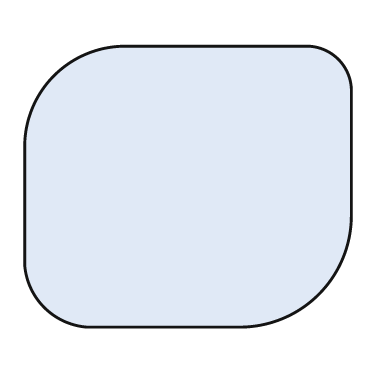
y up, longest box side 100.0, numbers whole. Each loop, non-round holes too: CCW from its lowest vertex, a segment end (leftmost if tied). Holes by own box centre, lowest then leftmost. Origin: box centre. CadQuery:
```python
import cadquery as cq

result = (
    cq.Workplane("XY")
    .moveTo(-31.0, -43.0)
    .lineTo(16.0, -43.0)
    .threePointArc((40.0, -33.0), (50.0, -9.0))
    .lineTo(50.0, 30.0)
    .threePointArc((46.0, 39.0), (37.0, 43.0))
    .lineTo(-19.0, 43.0)
    .threePointArc((-41.0, 34.0), (-50.0, 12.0))
    .lineTo(-50.0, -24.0)
    .threePointArc((-44.0, -37.0), (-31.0, -43.0))
    .close()
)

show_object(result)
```